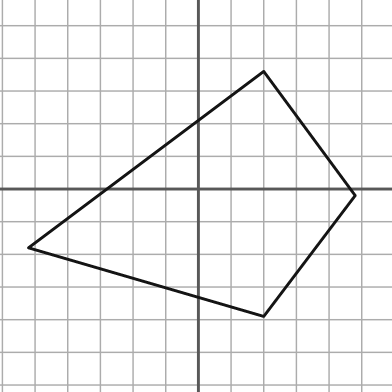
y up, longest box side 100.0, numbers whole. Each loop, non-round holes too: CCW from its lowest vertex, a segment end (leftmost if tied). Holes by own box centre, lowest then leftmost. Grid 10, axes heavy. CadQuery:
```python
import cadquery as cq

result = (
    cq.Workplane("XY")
    .moveTo(20.0, -39.0)
    .lineTo(48.0, -2.0)
    .lineTo(20.0, 36.0)
    .lineTo(-52.0, -18.0)
    .close()
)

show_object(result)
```